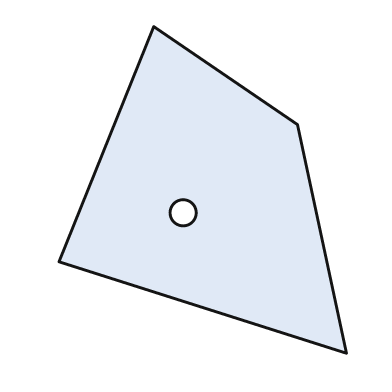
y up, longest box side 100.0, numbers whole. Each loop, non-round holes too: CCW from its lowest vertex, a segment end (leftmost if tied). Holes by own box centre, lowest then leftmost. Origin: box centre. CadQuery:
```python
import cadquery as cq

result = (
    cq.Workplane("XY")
    .moveTo(44.0, -50.0)
    .lineTo(29.0, 20.0)
    .lineTo(-15.0, 50.0)
    .lineTo(-44.0, -22.0)
    .close()
    .moveTo(-6.0, -7.0)
    .circle(4.0)
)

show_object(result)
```